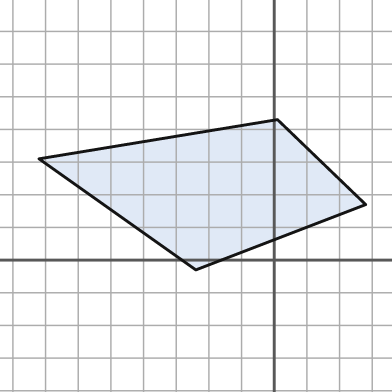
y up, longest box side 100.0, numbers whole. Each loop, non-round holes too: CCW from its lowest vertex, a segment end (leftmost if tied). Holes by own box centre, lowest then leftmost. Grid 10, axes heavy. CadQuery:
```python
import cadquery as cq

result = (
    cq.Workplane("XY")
    .moveTo(-24.0, -3.0)
    .lineTo(28.0, 17.0)
    .lineTo(1.0, 43.0)
    .lineTo(-72.0, 31.0)
    .close()
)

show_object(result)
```